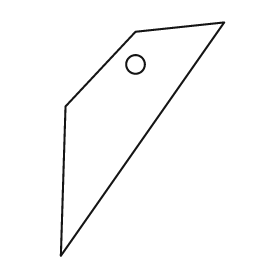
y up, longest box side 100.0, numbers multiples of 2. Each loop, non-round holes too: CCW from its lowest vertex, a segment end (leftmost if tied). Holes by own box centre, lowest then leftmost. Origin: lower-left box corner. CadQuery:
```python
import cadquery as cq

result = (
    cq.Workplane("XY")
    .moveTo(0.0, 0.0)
    .lineTo(70.0, 100.0)
    .lineTo(32.0, 96.0)
    .lineTo(2.0, 64.0)
    .close()
    .moveTo(32.0, 82.0)
    .circle(4.0)
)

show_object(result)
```